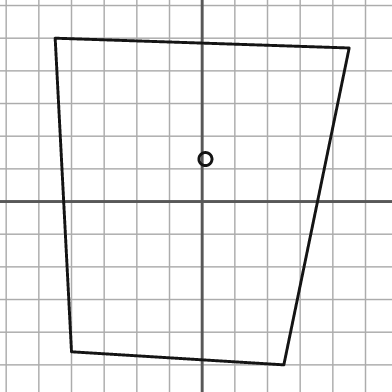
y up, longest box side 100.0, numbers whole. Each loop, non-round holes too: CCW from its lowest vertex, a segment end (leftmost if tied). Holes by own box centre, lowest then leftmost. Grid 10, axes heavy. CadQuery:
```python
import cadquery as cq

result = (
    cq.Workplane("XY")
    .moveTo(25.0, -50.0)
    .lineTo(45.0, 47.0)
    .lineTo(-45.0, 50.0)
    .lineTo(-40.0, -46.0)
    .close()
    .moveTo(1.0, 13.0)
    .circle(2.0)
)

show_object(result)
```